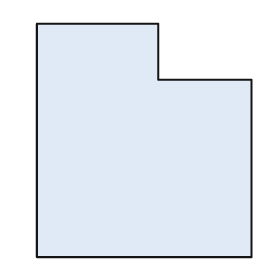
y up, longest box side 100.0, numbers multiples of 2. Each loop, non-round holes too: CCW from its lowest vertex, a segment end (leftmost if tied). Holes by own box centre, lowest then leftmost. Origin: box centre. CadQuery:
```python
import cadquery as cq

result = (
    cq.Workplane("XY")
    .moveTo(-46.0, -50.0)
    .lineTo(46.0, -50.0)
    .lineTo(46.0, 26.0)
    .lineTo(6.0, 26.0)
    .lineTo(6.0, 50.0)
    .lineTo(-46.0, 50.0)
    .close()
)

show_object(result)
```